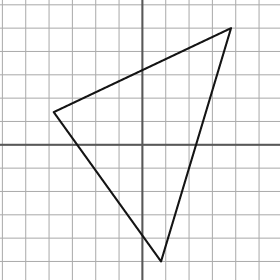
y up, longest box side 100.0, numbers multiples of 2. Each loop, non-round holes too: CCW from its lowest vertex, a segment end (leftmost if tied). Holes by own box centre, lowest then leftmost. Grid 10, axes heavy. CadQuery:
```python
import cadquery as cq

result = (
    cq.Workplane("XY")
    .moveTo(8.0, -50.0)
    .lineTo(38.0, 50.0)
    .lineTo(-38.0, 14.0)
    .close()
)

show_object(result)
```